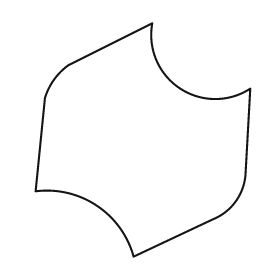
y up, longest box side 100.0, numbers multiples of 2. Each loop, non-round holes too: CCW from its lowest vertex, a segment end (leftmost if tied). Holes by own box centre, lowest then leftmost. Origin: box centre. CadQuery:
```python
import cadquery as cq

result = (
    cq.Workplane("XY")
    .moveTo(-4.0, -50.0)
    .lineTo(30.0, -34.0)
    .threePointArc((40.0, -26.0), (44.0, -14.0))
    .lineTo(46.0, 22.0)
    .threePointArc((16.0, 22.0), (4.0, 50.0))
    .lineTo(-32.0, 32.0)
    .threePointArc((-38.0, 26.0), (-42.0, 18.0))
    .lineTo(-46.0, -22.0)
    .threePointArc((-20.0, -28.0), (-4.0, -50.0))
    .close()
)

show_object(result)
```